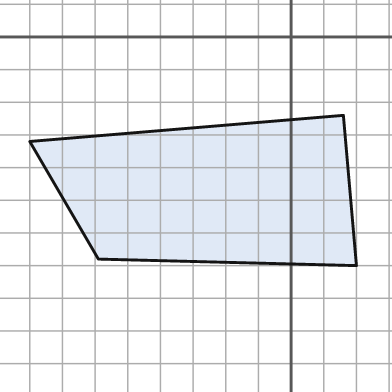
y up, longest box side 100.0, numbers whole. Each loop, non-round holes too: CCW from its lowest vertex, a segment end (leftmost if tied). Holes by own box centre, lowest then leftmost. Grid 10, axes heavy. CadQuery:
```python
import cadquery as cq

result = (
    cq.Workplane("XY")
    .moveTo(20.0, -70.0)
    .lineTo(16.0, -24.0)
    .lineTo(-80.0, -32.0)
    .lineTo(-59.0, -68.0)
    .close()
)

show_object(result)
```